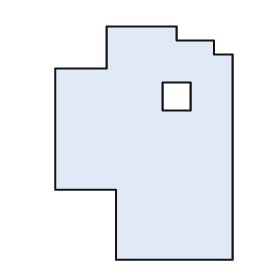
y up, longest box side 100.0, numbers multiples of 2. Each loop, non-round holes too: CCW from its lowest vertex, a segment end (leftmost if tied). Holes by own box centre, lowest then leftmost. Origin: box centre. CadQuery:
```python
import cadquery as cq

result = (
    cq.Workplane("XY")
    .moveTo(-12.0, -50.0)
    .lineTo(38.0, -50.0)
    .lineTo(38.0, 38.0)
    .lineTo(30.0, 38.0)
    .lineTo(30.0, 44.0)
    .lineTo(14.0, 44.0)
    .lineTo(14.0, 50.0)
    .lineTo(-16.0, 50.0)
    .lineTo(-16.0, 32.0)
    .lineTo(-38.0, 32.0)
    .lineTo(-38.0, -20.0)
    .lineTo(-12.0, -20.0)
    .close()
    .moveTo(8.0, 14.0)
    .lineTo(20.0, 14.0)
    .lineTo(20.0, 26.0)
    .lineTo(8.0, 26.0)
    .close()
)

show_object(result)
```